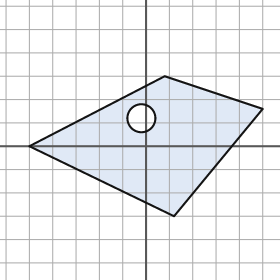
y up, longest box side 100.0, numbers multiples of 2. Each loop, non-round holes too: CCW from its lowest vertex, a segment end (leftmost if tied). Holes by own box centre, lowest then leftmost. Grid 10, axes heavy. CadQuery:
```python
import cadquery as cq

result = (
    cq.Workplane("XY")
    .moveTo(12.0, -30.0)
    .lineTo(50.0, 16.0)
    .lineTo(8.0, 30.0)
    .lineTo(-50.0, 0.0)
    .close()
    .moveTo(-2.0, 12.0)
    .circle(6.0)
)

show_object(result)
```